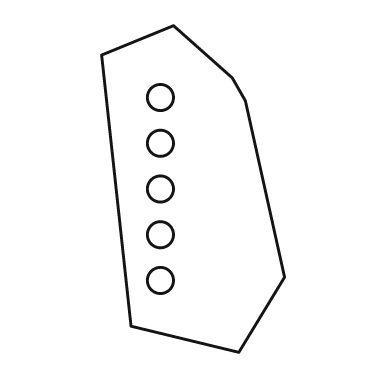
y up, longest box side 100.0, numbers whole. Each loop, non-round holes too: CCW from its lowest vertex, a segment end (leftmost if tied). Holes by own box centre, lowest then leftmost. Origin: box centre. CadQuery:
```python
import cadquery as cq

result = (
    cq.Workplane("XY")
    .moveTo(14.0, -50.0)
    .lineTo(28.0, -27.0)
    .lineTo(16.0, 27.0)
    .lineTo(12.0, 34.0)
    .lineTo(-6.0, 50.0)
    .lineTo(-28.0, 41.0)
    .lineTo(-19.0, -42.0)
    .close()
    .moveTo(-10.0, -28.0)
    .circle(4.0)
    .moveTo(-10.0, -14.0)
    .circle(4.0)
    .moveTo(-10.0, 0.0)
    .circle(4.0)
    .moveTo(-10.0, 14.0)
    .circle(4.0)
    .moveTo(-10.0, 28.0)
    .circle(4.0)
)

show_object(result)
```